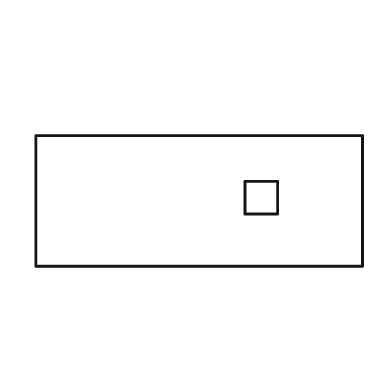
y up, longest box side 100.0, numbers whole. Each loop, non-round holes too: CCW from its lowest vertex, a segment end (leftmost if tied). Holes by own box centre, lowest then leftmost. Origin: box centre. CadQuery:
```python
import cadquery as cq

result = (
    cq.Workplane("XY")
    .moveTo(-50.0, -20.0)
    .lineTo(50.0, -20.0)
    .lineTo(50.0, 20.0)
    .lineTo(-50.0, 20.0)
    .close()
    .moveTo(14.0, -4.0)
    .lineTo(24.0, -4.0)
    .lineTo(24.0, 6.0)
    .lineTo(14.0, 6.0)
    .close()
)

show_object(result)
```